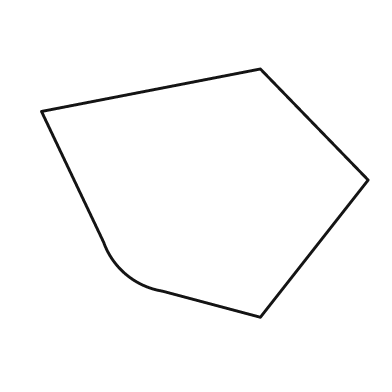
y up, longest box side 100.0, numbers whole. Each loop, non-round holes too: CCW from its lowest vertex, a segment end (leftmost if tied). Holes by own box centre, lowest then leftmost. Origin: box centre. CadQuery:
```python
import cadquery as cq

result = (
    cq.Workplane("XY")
    .moveTo(17.0, -38.0)
    .lineTo(50.0, 4.0)
    .lineTo(17.0, 38.0)
    .lineTo(-50.0, 25.0)
    .lineTo(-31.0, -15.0)
    .threePointArc((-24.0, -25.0), (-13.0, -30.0))
    .close()
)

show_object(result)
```